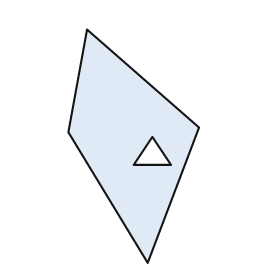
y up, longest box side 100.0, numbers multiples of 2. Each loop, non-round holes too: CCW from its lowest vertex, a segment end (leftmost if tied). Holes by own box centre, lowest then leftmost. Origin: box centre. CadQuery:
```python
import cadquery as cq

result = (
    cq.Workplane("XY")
    .moveTo(6.0, -50.0)
    .lineTo(28.0, 8.0)
    .lineTo(-20.0, 50.0)
    .lineTo(-28.0, 6.0)
    .close()
    .moveTo(0.0, -8.0)
    .lineTo(16.0, -8.0)
    .lineTo(8.0, 4.0)
    .close()
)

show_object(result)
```